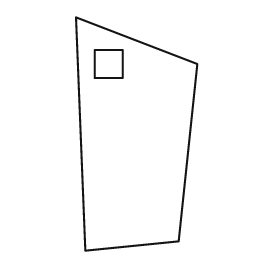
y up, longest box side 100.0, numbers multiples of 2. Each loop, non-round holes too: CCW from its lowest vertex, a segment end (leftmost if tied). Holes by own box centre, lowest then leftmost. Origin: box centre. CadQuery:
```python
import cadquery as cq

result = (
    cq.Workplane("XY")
    .moveTo(-22.0, -50.0)
    .lineTo(18.0, -46.0)
    .lineTo(26.0, 30.0)
    .lineTo(-26.0, 50.0)
    .close()
    .moveTo(-18.0, 24.0)
    .lineTo(-6.0, 24.0)
    .lineTo(-6.0, 36.0)
    .lineTo(-18.0, 36.0)
    .close()
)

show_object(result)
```